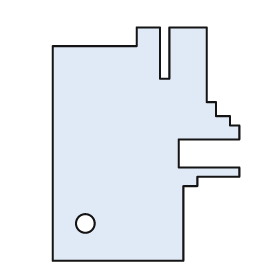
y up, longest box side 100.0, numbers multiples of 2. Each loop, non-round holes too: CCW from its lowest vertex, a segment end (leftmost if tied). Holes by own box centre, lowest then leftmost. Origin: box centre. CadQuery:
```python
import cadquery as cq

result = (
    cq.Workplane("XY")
    .moveTo(-40.0, -50.0)
    .lineTo(16.0, -50.0)
    .lineTo(16.0, -18.0)
    .lineTo(22.0, -18.0)
    .lineTo(22.0, -14.0)
    .lineTo(40.0, -14.0)
    .lineTo(40.0, -10.0)
    .lineTo(14.0, -10.0)
    .lineTo(14.0, 2.0)
    .lineTo(40.0, 2.0)
    .lineTo(40.0, 8.0)
    .lineTo(36.0, 8.0)
    .lineTo(36.0, 12.0)
    .lineTo(30.0, 12.0)
    .lineTo(30.0, 18.0)
    .lineTo(26.0, 18.0)
    .lineTo(26.0, 50.0)
    .lineTo(10.0, 50.0)
    .lineTo(10.0, 28.0)
    .lineTo(6.0, 28.0)
    .lineTo(6.0, 50.0)
    .lineTo(-4.0, 50.0)
    .lineTo(-4.0, 42.0)
    .lineTo(-40.0, 42.0)
    .close()
    .moveTo(-26.0, -34.0)
    .circle(4.0)
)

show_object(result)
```